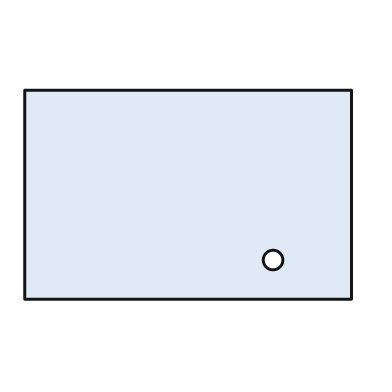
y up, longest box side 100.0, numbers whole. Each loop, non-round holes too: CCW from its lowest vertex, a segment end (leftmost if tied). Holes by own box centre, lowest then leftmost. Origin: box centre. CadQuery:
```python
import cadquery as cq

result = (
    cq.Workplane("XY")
    .moveTo(-50.0, -32.0)
    .lineTo(50.0, -32.0)
    .lineTo(50.0, 32.0)
    .lineTo(-50.0, 32.0)
    .close()
    .moveTo(26.0, -20.0)
    .circle(3.0)
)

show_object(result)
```